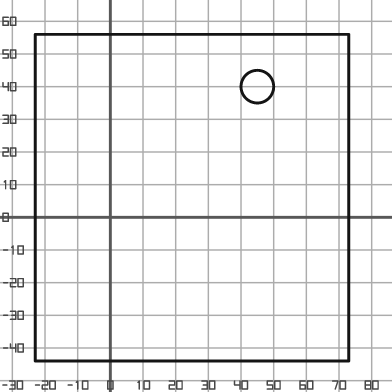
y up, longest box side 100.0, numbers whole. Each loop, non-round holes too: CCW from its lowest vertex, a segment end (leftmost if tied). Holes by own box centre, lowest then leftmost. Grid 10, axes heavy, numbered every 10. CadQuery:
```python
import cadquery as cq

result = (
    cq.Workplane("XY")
    .moveTo(-23.0, -44.0)
    .lineTo(73.0, -44.0)
    .lineTo(73.0, 56.0)
    .lineTo(-23.0, 56.0)
    .close()
    .moveTo(45.0, 40.0)
    .circle(5.0)
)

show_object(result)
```